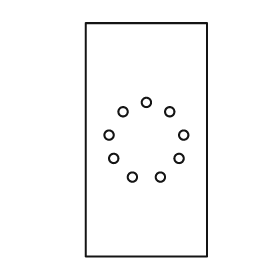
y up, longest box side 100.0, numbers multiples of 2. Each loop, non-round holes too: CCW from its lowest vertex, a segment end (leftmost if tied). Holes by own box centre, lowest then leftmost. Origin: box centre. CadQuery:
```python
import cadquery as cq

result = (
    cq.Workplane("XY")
    .moveTo(-26.0, -50.0)
    .lineTo(26.0, -50.0)
    .lineTo(26.0, 50.0)
    .lineTo(-26.0, 50.0)
    .close()
    .moveTo(-6.0, -16.0)
    .circle(2.0)
    .moveTo(6.0, -16.0)
    .circle(2.0)
    .moveTo(-14.0, -8.0)
    .circle(2.0)
    .moveTo(14.0, -8.0)
    .circle(2.0)
    .moveTo(-16.0, 2.0)
    .circle(2.0)
    .moveTo(16.0, 2.0)
    .circle(2.0)
    .moveTo(-10.0, 12.0)
    .circle(2.0)
    .moveTo(10.0, 12.0)
    .circle(2.0)
    .moveTo(0.0, 16.0)
    .circle(2.0)
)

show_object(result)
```